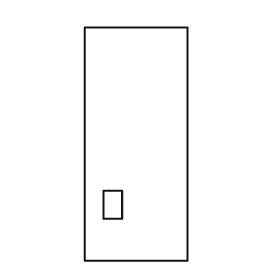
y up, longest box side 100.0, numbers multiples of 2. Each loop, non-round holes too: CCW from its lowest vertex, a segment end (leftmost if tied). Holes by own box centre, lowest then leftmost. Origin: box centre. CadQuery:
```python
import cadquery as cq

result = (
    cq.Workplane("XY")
    .moveTo(-22.0, -50.0)
    .lineTo(22.0, -50.0)
    .lineTo(22.0, 50.0)
    .lineTo(-22.0, 50.0)
    .close()
    .moveTo(-14.0, -32.0)
    .lineTo(-6.0, -32.0)
    .lineTo(-6.0, -20.0)
    .lineTo(-14.0, -20.0)
    .close()
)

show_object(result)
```